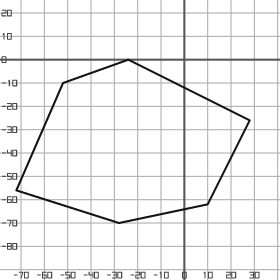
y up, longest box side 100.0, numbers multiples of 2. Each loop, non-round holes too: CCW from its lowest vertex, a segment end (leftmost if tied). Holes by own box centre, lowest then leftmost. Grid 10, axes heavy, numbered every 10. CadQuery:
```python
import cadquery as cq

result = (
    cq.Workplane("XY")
    .moveTo(-28.0, -70.0)
    .lineTo(10.0, -62.0)
    .lineTo(28.0, -26.0)
    .lineTo(-24.0, 0.0)
    .lineTo(-52.0, -10.0)
    .lineTo(-72.0, -56.0)
    .close()
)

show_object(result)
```